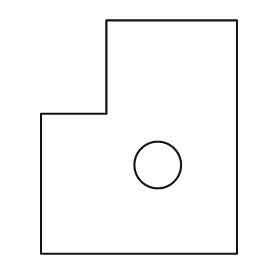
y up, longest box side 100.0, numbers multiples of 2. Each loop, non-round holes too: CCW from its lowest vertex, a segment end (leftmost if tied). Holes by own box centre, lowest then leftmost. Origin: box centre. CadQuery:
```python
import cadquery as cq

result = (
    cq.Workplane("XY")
    .moveTo(-42.0, -50.0)
    .lineTo(42.0, -50.0)
    .lineTo(42.0, 50.0)
    .lineTo(-14.0, 50.0)
    .lineTo(-14.0, 10.0)
    .lineTo(-42.0, 10.0)
    .close()
    .moveTo(8.0, -12.0)
    .circle(10.0)
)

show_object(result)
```